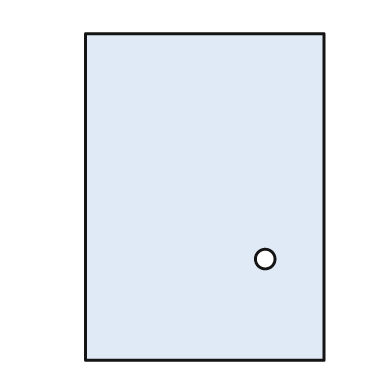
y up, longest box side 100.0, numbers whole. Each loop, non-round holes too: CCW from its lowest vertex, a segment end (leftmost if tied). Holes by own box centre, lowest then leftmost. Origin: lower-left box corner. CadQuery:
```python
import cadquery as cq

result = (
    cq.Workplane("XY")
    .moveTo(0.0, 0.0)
    .lineTo(73.0, 0.0)
    .lineTo(73.0, 100.0)
    .lineTo(0.0, 100.0)
    .close()
    .moveTo(55.0, 31.0)
    .circle(3.0)
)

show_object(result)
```